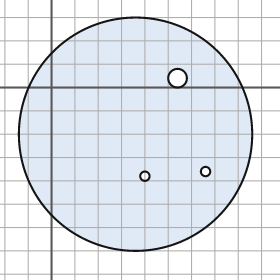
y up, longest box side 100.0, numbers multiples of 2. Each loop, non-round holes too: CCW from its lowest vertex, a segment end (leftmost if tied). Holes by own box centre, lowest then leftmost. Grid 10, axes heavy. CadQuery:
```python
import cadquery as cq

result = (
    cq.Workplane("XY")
    .moveTo(36.0, -20.0)
    .circle(50.0)
    .moveTo(40.0, -38.0)
    .circle(2.0)
    .moveTo(66.0, -36.0)
    .circle(2.0)
    .moveTo(54.0, 4.0)
    .circle(4.0)
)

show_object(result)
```